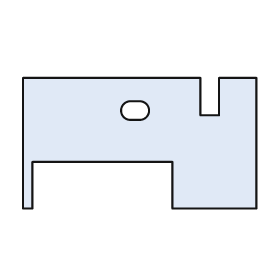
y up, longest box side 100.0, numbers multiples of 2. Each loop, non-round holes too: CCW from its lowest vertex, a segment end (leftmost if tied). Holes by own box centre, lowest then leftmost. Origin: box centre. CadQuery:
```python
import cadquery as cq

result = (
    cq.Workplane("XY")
    .moveTo(-50.0, -28.0)
    .lineTo(-46.0, -28.0)
    .lineTo(-46.0, -8.0)
    .lineTo(14.0, -8.0)
    .lineTo(14.0, -28.0)
    .lineTo(50.0, -28.0)
    .lineTo(50.0, 28.0)
    .lineTo(34.0, 28.0)
    .lineTo(34.0, 12.0)
    .lineTo(26.0, 12.0)
    .lineTo(26.0, 28.0)
    .lineTo(-50.0, 28.0)
    .close()
    .moveTo(-4.0, 10.0)
    .lineTo(0.0, 10.0)
    .threePointArc((4.0, 14.0), (0.0, 18.0))
    .lineTo(-4.0, 18.0)
    .threePointArc((-8.0, 14.0), (-4.0, 10.0))
    .close()
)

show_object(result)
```